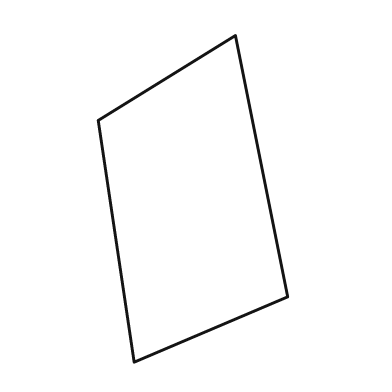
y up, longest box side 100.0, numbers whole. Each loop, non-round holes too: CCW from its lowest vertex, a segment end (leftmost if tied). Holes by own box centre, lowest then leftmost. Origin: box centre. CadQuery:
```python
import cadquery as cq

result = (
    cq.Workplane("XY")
    .moveTo(-18.0, -50.0)
    .lineTo(29.0, -30.0)
    .lineTo(13.0, 50.0)
    .lineTo(-29.0, 24.0)
    .close()
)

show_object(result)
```